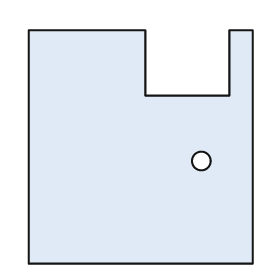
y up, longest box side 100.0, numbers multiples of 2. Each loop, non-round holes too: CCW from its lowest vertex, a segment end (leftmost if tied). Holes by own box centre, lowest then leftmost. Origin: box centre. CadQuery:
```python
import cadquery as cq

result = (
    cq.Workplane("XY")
    .moveTo(-48.0, -50.0)
    .lineTo(48.0, -50.0)
    .lineTo(48.0, 50.0)
    .lineTo(38.0, 50.0)
    .lineTo(38.0, 22.0)
    .lineTo(2.0, 22.0)
    .lineTo(2.0, 50.0)
    .lineTo(-48.0, 50.0)
    .close()
    .moveTo(26.0, -6.0)
    .circle(4.0)
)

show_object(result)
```